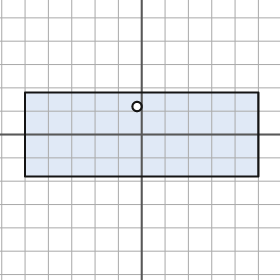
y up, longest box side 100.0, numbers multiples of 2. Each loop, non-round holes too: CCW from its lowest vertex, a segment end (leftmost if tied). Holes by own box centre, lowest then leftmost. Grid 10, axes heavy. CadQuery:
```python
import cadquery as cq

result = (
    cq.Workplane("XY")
    .moveTo(-50.0, -18.0)
    .lineTo(50.0, -18.0)
    .lineTo(50.0, 18.0)
    .lineTo(-50.0, 18.0)
    .close()
    .moveTo(-2.0, 12.0)
    .circle(2.0)
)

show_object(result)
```